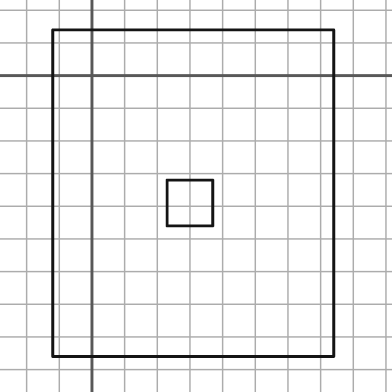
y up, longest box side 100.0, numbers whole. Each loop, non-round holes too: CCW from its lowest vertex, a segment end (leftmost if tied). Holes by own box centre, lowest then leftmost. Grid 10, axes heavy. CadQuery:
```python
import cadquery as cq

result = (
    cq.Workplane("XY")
    .moveTo(-12.0, -86.0)
    .lineTo(74.0, -86.0)
    .lineTo(74.0, 14.0)
    .lineTo(-12.0, 14.0)
    .close()
    .moveTo(23.0, -46.0)
    .lineTo(37.0, -46.0)
    .lineTo(37.0, -32.0)
    .lineTo(23.0, -32.0)
    .close()
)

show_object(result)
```